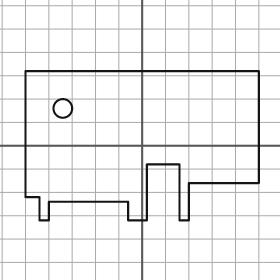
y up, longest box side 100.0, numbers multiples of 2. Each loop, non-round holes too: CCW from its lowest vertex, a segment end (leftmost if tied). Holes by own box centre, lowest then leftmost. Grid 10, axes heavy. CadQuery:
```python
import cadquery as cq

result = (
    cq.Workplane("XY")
    .moveTo(-44.0, -32.0)
    .lineTo(-40.0, -32.0)
    .lineTo(-40.0, -24.0)
    .lineTo(-6.0, -24.0)
    .lineTo(-6.0, -32.0)
    .lineTo(2.0, -32.0)
    .lineTo(2.0, -8.0)
    .lineTo(16.0, -8.0)
    .lineTo(16.0, -32.0)
    .lineTo(20.0, -32.0)
    .lineTo(20.0, -16.0)
    .lineTo(50.0, -16.0)
    .lineTo(50.0, 32.0)
    .lineTo(-50.0, 32.0)
    .lineTo(-50.0, -22.0)
    .lineTo(-44.0, -22.0)
    .close()
    .moveTo(-34.0, 16.0)
    .circle(4.0)
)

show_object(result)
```